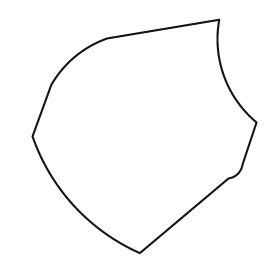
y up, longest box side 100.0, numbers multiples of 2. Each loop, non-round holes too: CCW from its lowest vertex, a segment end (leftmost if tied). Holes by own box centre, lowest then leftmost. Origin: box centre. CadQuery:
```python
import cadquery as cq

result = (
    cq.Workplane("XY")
    .moveTo(-2.0, -50.0)
    .lineTo(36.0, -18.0)
    .threePointArc((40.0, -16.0), (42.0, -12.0))
    .lineTo(48.0, 6.0)
    .threePointArc((34.0, 26.0), (32.0, 50.0))
    .lineTo(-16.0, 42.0)
    .threePointArc((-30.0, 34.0), (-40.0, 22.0))
    .lineTo(-48.0, 0.0)
    .threePointArc((-30.0, -30.0), (-2.0, -50.0))
    .close()
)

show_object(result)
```